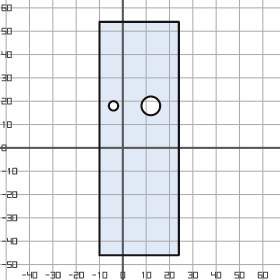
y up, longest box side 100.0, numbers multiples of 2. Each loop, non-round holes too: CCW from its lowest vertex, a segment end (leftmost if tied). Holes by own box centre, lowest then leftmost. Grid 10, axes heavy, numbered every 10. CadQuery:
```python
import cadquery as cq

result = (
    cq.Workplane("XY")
    .moveTo(-10.0, -46.0)
    .lineTo(24.0, -46.0)
    .lineTo(24.0, 54.0)
    .lineTo(-10.0, 54.0)
    .close()
    .moveTo(-4.0, 18.0)
    .circle(2.0)
    .moveTo(12.0, 18.0)
    .circle(4.0)
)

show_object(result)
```